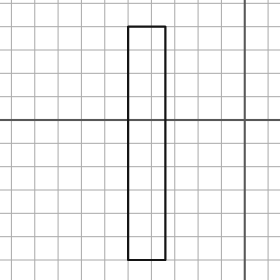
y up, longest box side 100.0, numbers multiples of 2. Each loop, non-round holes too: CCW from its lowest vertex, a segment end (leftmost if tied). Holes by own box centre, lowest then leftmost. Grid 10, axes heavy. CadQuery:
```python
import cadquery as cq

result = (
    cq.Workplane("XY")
    .moveTo(-50.0, -60.0)
    .lineTo(-34.0, -60.0)
    .lineTo(-34.0, 40.0)
    .lineTo(-50.0, 40.0)
    .close()
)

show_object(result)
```